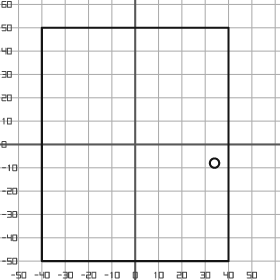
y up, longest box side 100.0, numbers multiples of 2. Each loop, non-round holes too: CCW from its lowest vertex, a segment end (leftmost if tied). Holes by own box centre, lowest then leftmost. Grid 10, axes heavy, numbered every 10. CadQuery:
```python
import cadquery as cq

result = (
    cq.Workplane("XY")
    .moveTo(-40.0, -50.0)
    .lineTo(40.0, -50.0)
    .lineTo(40.0, 50.0)
    .lineTo(-40.0, 50.0)
    .close()
    .moveTo(34.0, -8.0)
    .circle(2.0)
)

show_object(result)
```